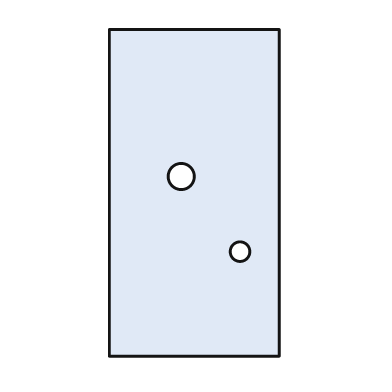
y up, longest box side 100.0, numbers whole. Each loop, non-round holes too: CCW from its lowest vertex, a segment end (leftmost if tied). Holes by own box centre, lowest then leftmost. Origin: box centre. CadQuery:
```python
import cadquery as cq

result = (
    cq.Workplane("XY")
    .moveTo(-26.0, -50.0)
    .lineTo(26.0, -50.0)
    .lineTo(26.0, 50.0)
    .lineTo(-26.0, 50.0)
    .close()
    .moveTo(14.0, -18.0)
    .circle(3.0)
    .moveTo(-4.0, 5.0)
    .circle(4.0)
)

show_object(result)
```